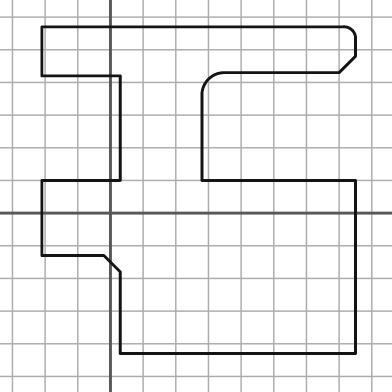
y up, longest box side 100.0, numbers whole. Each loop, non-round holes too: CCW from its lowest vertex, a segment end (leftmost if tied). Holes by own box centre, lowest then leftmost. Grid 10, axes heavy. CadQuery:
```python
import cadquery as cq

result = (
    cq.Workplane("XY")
    .moveTo(3.0, -43.0)
    .lineTo(75.0, -43.0)
    .lineTo(75.0, 10.0)
    .lineTo(28.0, 10.0)
    .lineTo(28.0, 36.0)
    .threePointArc((30.0, 41.0), (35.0, 43.0))
    .lineTo(70.0, 43.0)
    .lineTo(75.0, 48.0)
    .lineTo(75.0, 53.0)
    .threePointArc((74.0, 56.0), (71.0, 57.0))
    .lineTo(-21.0, 57.0)
    .lineTo(-21.0, 42.0)
    .lineTo(3.0, 42.0)
    .lineTo(3.0, 10.0)
    .lineTo(-21.0, 10.0)
    .lineTo(-21.0, -13.0)
    .lineTo(-2.0, -13.0)
    .lineTo(3.0, -18.0)
    .close()
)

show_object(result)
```